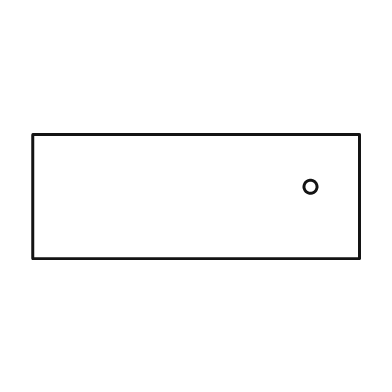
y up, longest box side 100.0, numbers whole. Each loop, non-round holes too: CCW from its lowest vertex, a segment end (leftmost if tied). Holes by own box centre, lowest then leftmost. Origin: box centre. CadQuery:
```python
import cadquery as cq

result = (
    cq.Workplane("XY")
    .moveTo(-50.0, -19.0)
    .lineTo(50.0, -19.0)
    .lineTo(50.0, 19.0)
    .lineTo(-50.0, 19.0)
    .close()
    .moveTo(35.0, 3.0)
    .circle(2.0)
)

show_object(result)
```